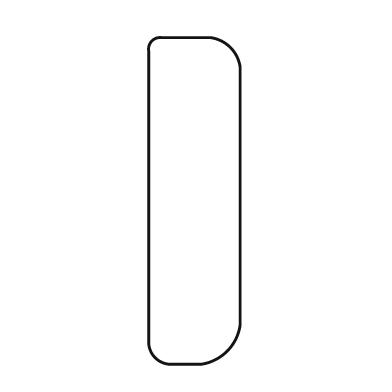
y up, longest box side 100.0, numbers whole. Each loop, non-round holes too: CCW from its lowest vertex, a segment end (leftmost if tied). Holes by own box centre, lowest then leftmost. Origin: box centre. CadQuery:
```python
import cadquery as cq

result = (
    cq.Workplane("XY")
    .moveTo(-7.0, -50.0)
    .lineTo(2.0, -50.0)
    .threePointArc((10.0, -46.0), (14.0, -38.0))
    .lineTo(14.0, 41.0)
    .threePointArc((11.0, 47.0), (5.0, 50.0))
    .lineTo(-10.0, 50.0)
    .threePointArc((-13.0, 49.0), (-14.0, 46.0))
    .lineTo(-14.0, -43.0)
    .threePointArc((-12.0, -48.0), (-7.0, -50.0))
    .close()
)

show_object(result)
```